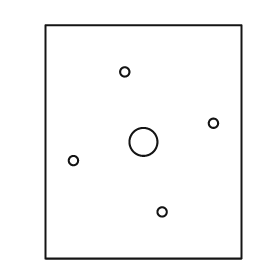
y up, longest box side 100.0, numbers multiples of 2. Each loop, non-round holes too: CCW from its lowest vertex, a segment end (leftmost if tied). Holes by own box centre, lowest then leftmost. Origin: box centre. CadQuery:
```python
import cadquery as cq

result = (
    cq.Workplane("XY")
    .moveTo(-42.0, -50.0)
    .lineTo(42.0, -50.0)
    .lineTo(42.0, 50.0)
    .lineTo(-42.0, 50.0)
    .close()
    .moveTo(8.0, -30.0)
    .circle(2.0)
    .moveTo(-30.0, -8.0)
    .circle(2.0)
    .moveTo(0.0, 0.0)
    .circle(6.0)
    .moveTo(30.0, 8.0)
    .circle(2.0)
    .moveTo(-8.0, 30.0)
    .circle(2.0)
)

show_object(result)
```